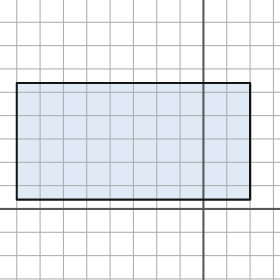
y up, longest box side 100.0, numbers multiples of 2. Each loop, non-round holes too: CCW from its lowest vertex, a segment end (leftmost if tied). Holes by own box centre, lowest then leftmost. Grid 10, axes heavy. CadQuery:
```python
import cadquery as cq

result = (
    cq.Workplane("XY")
    .moveTo(-80.0, 4.0)
    .lineTo(20.0, 4.0)
    .lineTo(20.0, 54.0)
    .lineTo(-80.0, 54.0)
    .close()
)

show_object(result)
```